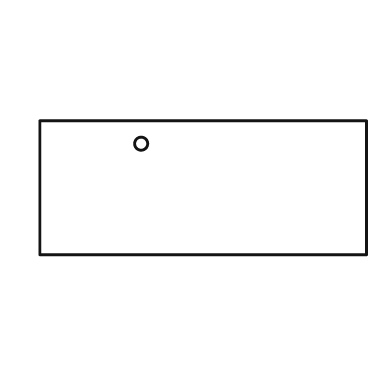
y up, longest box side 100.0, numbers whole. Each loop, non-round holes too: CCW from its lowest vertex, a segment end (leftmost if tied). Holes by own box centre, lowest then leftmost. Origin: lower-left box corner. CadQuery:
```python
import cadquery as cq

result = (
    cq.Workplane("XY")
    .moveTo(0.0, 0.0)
    .lineTo(100.0, 0.0)
    .lineTo(100.0, 41.0)
    .lineTo(0.0, 41.0)
    .close()
    .moveTo(31.0, 34.0)
    .circle(2.0)
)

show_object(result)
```